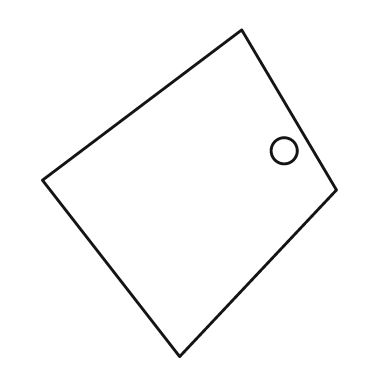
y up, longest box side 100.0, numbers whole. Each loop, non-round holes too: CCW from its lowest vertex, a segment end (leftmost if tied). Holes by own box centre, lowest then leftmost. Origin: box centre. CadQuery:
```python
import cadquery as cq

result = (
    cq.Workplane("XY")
    .moveTo(-3.0, -50.0)
    .lineTo(45.0, 1.0)
    .lineTo(16.0, 50.0)
    .lineTo(-45.0, 4.0)
    .close()
    .moveTo(29.0, 13.0)
    .circle(4.0)
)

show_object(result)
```